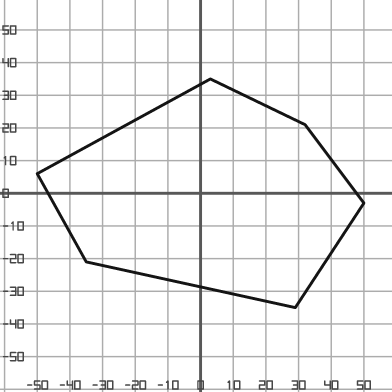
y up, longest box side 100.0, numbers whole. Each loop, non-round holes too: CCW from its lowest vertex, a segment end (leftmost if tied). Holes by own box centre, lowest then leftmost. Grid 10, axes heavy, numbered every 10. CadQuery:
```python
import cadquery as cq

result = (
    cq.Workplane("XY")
    .moveTo(29.0, -35.0)
    .lineTo(50.0, -3.0)
    .lineTo(32.0, 21.0)
    .lineTo(3.0, 35.0)
    .lineTo(-50.0, 6.0)
    .lineTo(-35.0, -21.0)
    .close()
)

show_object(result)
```